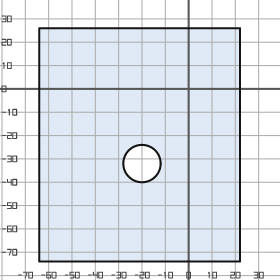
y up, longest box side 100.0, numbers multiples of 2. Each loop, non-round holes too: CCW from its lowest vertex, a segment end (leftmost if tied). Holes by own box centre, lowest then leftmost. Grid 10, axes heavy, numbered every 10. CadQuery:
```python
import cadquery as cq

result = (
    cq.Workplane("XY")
    .moveTo(-64.0, -74.0)
    .lineTo(22.0, -74.0)
    .lineTo(22.0, 26.0)
    .lineTo(-64.0, 26.0)
    .close()
    .moveTo(-20.0, -32.0)
    .circle(8.0)
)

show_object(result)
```